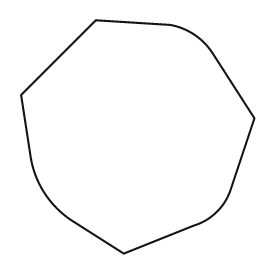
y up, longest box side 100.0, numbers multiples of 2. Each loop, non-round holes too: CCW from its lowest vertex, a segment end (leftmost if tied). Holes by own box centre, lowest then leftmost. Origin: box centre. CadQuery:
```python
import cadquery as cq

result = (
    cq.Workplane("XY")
    .moveTo(-6.0, -50.0)
    .lineTo(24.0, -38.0)
    .threePointArc((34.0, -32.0), (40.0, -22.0))
    .lineTo(50.0, 8.0)
    .lineTo(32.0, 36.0)
    .threePointArc((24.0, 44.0), (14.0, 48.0))
    .lineTo(-18.0, 50.0)
    .lineTo(-50.0, 18.0)
    .lineTo(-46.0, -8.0)
    .threePointArc((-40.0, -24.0), (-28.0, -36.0))
    .close()
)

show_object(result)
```